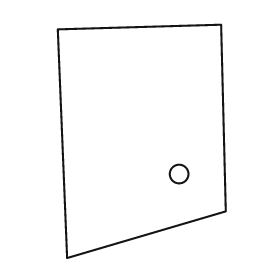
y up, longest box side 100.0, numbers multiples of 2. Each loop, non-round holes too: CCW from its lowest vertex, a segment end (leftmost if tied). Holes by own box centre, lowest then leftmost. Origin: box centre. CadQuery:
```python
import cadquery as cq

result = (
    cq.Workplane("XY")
    .moveTo(-32.0, -50.0)
    .lineTo(36.0, -30.0)
    .lineTo(34.0, 50.0)
    .lineTo(-36.0, 48.0)
    .close()
    .moveTo(16.0, -14.0)
    .circle(4.0)
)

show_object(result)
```